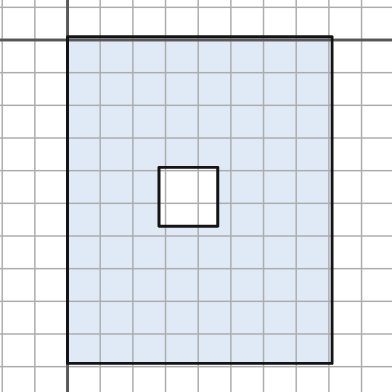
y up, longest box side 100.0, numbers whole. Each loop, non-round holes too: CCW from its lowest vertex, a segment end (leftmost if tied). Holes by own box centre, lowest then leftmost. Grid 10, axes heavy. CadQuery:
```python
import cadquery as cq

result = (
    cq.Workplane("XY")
    .moveTo(0.0, -99.0)
    .lineTo(81.0, -99.0)
    .lineTo(81.0, 1.0)
    .lineTo(0.0, 1.0)
    .close()
    .moveTo(28.0, -57.0)
    .lineTo(46.0, -57.0)
    .lineTo(46.0, -39.0)
    .lineTo(28.0, -39.0)
    .close()
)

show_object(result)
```